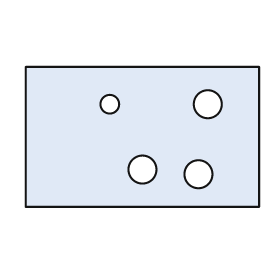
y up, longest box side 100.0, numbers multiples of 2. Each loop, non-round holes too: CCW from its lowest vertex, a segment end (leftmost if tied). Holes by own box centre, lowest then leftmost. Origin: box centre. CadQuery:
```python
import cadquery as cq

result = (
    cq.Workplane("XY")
    .moveTo(-50.0, -30.0)
    .lineTo(50.0, -30.0)
    .lineTo(50.0, 30.0)
    .lineTo(-50.0, 30.0)
    .close()
    .moveTo(24.0, -16.0)
    .circle(6.0)
    .moveTo(0.0, -14.0)
    .circle(6.0)
    .moveTo(-14.0, 14.0)
    .circle(4.0)
    .moveTo(28.0, 14.0)
    .circle(6.0)
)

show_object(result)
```